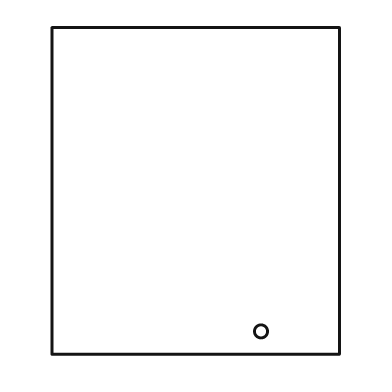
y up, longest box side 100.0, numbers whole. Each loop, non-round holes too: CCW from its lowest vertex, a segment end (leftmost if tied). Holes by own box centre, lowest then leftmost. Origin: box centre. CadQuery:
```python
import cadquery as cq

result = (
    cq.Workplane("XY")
    .moveTo(-44.0, -50.0)
    .lineTo(44.0, -50.0)
    .lineTo(44.0, 50.0)
    .lineTo(-44.0, 50.0)
    .close()
    .moveTo(20.0, -43.0)
    .circle(2.0)
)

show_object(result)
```